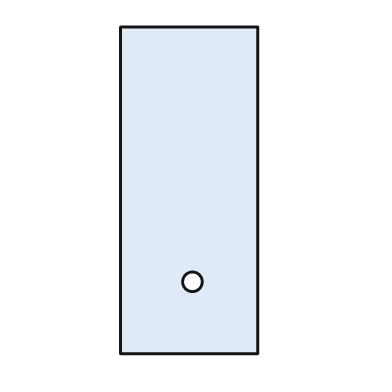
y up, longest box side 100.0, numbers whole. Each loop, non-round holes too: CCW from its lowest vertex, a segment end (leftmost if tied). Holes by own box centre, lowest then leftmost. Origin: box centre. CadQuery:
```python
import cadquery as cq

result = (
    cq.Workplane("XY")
    .moveTo(-21.0, -50.0)
    .lineTo(21.0, -50.0)
    .lineTo(21.0, 50.0)
    .lineTo(-21.0, 50.0)
    .close()
    .moveTo(1.0, -28.0)
    .circle(3.0)
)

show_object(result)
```